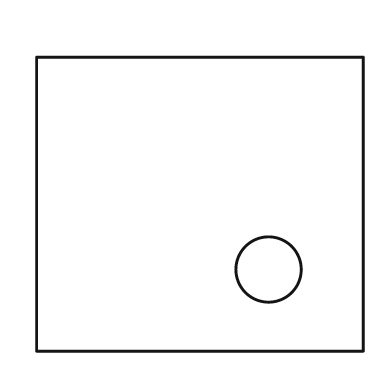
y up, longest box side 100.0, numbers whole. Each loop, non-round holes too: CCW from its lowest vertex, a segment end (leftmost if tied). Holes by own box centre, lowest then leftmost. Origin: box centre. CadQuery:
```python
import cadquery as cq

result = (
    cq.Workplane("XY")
    .moveTo(-50.0, -45.0)
    .lineTo(50.0, -45.0)
    .lineTo(50.0, 45.0)
    .lineTo(-50.0, 45.0)
    .close()
    .moveTo(21.0, -20.0)
    .circle(10.0)
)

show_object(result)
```